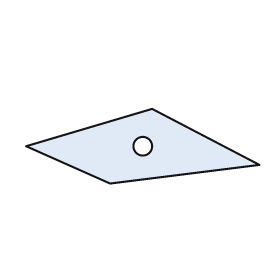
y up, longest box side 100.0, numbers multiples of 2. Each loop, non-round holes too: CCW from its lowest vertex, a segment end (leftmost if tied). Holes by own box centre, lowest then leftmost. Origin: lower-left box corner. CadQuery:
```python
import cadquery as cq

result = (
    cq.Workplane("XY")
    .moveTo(36.0, 0.0)
    .lineTo(100.0, 8.0)
    .lineTo(54.0, 32.0)
    .lineTo(0.0, 16.0)
    .close()
    .moveTo(50.0, 16.0)
    .circle(4.0)
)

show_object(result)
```